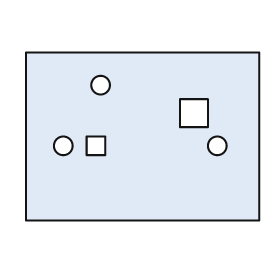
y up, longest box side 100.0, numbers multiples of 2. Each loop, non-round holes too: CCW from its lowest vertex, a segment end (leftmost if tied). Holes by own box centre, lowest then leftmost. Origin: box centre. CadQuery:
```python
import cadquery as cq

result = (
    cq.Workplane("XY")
    .moveTo(-50.0, -36.0)
    .lineTo(50.0, -36.0)
    .lineTo(50.0, 36.0)
    .lineTo(-50.0, 36.0)
    .close()
    .moveTo(-34.0, -4.0)
    .circle(4.0)
    .moveTo(-24.0, -8.0)
    .lineTo(-16.0, -8.0)
    .lineTo(-16.0, 0.0)
    .lineTo(-24.0, 0.0)
    .close()
    .moveTo(32.0, -4.0)
    .circle(4.0)
    .moveTo(16.0, 4.0)
    .lineTo(28.0, 4.0)
    .lineTo(28.0, 16.0)
    .lineTo(16.0, 16.0)
    .close()
    .moveTo(-18.0, 22.0)
    .circle(4.0)
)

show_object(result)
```